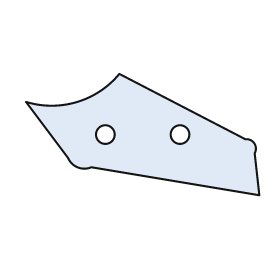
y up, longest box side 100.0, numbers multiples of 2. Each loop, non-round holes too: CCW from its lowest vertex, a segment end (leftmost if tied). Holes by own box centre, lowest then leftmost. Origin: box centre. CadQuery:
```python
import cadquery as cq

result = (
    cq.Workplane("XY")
    .moveTo(50.0, -26.0)
    .lineTo(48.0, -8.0)
    .threePointArc((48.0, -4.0), (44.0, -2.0))
    .lineTo(-10.0, 26.0)
    .threePointArc((-28.0, 14.0), (-50.0, 14.0))
    .lineTo(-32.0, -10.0)
    .threePointArc((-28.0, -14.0), (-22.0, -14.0))
    .close()
    .moveTo(-16.0, 0.0)
    .circle(4.0)
    .moveTo(16.0, 0.0)
    .circle(4.0)
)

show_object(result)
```